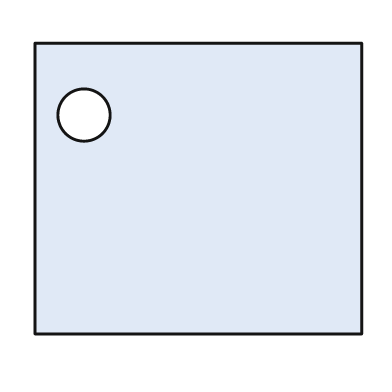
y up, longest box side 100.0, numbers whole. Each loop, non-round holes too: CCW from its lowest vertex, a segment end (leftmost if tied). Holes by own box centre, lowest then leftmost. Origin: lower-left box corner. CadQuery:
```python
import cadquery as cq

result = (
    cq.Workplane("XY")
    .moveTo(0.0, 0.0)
    .lineTo(100.0, 0.0)
    .lineTo(100.0, 89.0)
    .lineTo(0.0, 89.0)
    .close()
    .moveTo(15.0, 67.0)
    .circle(8.0)
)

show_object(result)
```